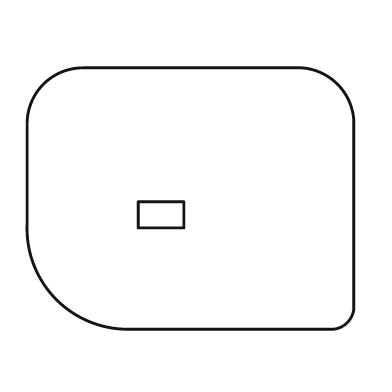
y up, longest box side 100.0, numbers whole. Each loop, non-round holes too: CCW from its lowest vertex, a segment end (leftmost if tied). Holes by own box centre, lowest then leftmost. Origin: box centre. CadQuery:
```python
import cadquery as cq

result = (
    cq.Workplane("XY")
    .moveTo(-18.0, -40.0)
    .lineTo(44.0, -40.0)
    .threePointArc((48.0, -38.0), (50.0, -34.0))
    .lineTo(50.0, 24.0)
    .threePointArc((45.0, 35.0), (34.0, 40.0))
    .lineTo(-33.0, 40.0)
    .threePointArc((-45.0, 35.0), (-50.0, 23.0))
    .lineTo(-50.0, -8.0)
    .threePointArc((-41.0, -31.0), (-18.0, -40.0))
    .close()
    .moveTo(-16.0, -9.0)
    .lineTo(-2.0, -9.0)
    .lineTo(-2.0, -1.0)
    .lineTo(-16.0, -1.0)
    .close()
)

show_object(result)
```